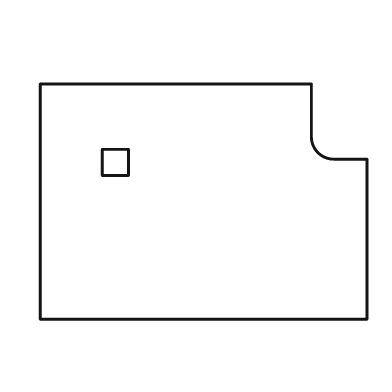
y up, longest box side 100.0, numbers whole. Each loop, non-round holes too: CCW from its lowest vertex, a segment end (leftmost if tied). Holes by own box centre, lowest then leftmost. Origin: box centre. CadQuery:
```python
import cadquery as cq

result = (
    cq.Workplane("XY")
    .moveTo(-50.0, -36.0)
    .lineTo(50.0, -36.0)
    .lineTo(50.0, 13.0)
    .lineTo(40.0, 13.0)
    .threePointArc((35.0, 15.0), (33.0, 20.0))
    .lineTo(33.0, 36.0)
    .lineTo(-50.0, 36.0)
    .close()
    .moveTo(-31.0, 8.0)
    .lineTo(-23.0, 8.0)
    .lineTo(-23.0, 16.0)
    .lineTo(-31.0, 16.0)
    .close()
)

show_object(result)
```